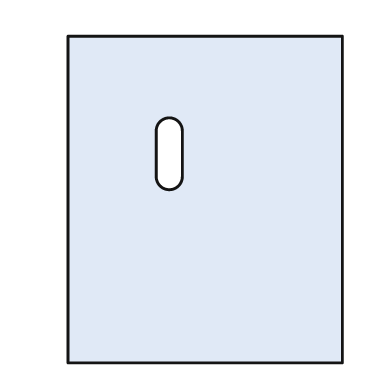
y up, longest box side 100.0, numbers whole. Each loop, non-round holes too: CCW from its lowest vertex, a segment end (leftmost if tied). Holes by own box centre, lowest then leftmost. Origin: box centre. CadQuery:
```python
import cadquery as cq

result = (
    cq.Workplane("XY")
    .moveTo(-42.0, -50.0)
    .lineTo(42.0, -50.0)
    .lineTo(42.0, 50.0)
    .lineTo(-42.0, 50.0)
    .close()
    .moveTo(-15.0, 7.0)
    .threePointArc((-11.0, 3.0), (-7.0, 7.0))
    .lineTo(-7.0, 21.0)
    .threePointArc((-11.0, 25.0), (-15.0, 21.0))
    .close()
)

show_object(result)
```